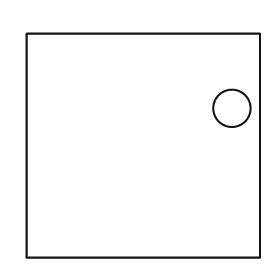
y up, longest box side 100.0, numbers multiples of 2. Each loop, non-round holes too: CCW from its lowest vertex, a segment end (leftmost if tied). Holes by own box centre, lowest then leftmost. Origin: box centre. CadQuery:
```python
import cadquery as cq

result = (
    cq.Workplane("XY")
    .moveTo(-50.0, -48.0)
    .lineTo(50.0, -48.0)
    .lineTo(50.0, 48.0)
    .lineTo(-50.0, 48.0)
    .close()
    .moveTo(38.0, 16.0)
    .circle(8.0)
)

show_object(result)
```